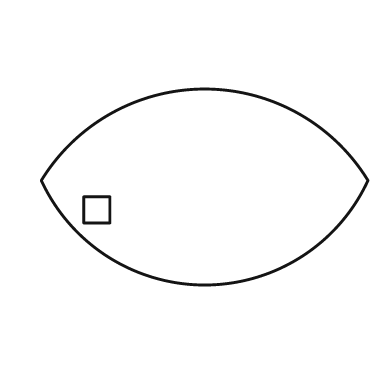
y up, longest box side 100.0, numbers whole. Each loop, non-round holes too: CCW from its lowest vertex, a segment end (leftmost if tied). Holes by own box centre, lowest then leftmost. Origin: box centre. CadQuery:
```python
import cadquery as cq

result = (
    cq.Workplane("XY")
    .moveTo(-50.0, 2.0)
    .threePointArc((0.0, -30.0), (50.0, 2.0))
    .threePointArc((0.0, 30.0), (-50.0, 2.0))
    .close()
    .moveTo(-37.0, -11.0)
    .lineTo(-29.0, -11.0)
    .lineTo(-29.0, -3.0)
    .lineTo(-37.0, -3.0)
    .close()
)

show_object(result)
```